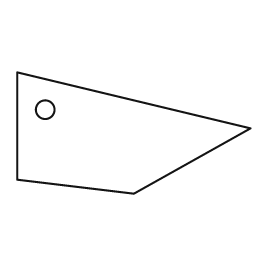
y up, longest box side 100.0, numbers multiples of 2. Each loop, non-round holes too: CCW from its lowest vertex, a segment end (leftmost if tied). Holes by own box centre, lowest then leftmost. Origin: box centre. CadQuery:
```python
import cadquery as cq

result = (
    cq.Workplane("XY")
    .moveTo(0.0, -26.0)
    .lineTo(50.0, 2.0)
    .lineTo(-50.0, 26.0)
    .lineTo(-50.0, -20.0)
    .close()
    .moveTo(-38.0, 10.0)
    .circle(4.0)
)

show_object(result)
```